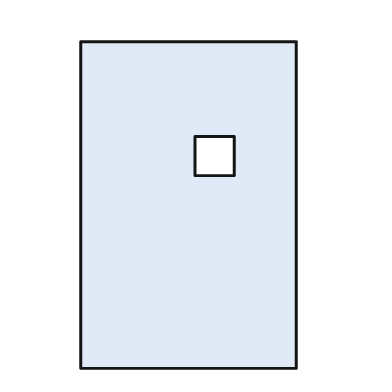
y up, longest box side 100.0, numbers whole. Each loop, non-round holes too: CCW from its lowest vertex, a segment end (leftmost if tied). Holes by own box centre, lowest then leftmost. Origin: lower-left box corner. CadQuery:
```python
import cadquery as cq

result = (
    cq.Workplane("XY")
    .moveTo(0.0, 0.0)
    .lineTo(66.0, 0.0)
    .lineTo(66.0, 100.0)
    .lineTo(0.0, 100.0)
    .close()
    .moveTo(35.0, 59.0)
    .lineTo(47.0, 59.0)
    .lineTo(47.0, 71.0)
    .lineTo(35.0, 71.0)
    .close()
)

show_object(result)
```